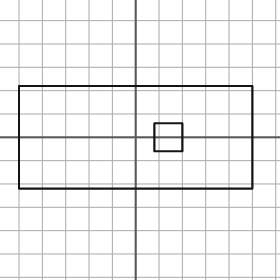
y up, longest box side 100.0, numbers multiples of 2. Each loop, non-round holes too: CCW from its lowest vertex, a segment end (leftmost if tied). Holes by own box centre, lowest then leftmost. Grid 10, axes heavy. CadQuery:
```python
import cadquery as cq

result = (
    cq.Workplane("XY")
    .moveTo(-50.0, -22.0)
    .lineTo(50.0, -22.0)
    .lineTo(50.0, 22.0)
    .lineTo(-50.0, 22.0)
    .close()
    .moveTo(8.0, -6.0)
    .lineTo(20.0, -6.0)
    .lineTo(20.0, 6.0)
    .lineTo(8.0, 6.0)
    .close()
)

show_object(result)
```